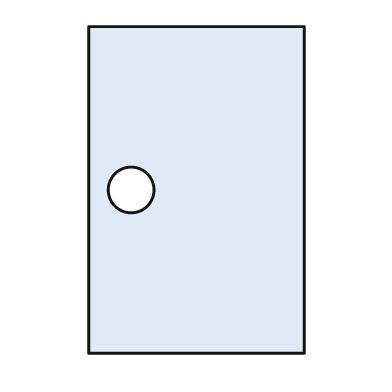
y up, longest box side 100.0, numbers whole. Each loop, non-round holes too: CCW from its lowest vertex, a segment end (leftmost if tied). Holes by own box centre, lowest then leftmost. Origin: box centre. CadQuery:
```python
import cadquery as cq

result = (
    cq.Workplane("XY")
    .moveTo(-33.0, -50.0)
    .lineTo(33.0, -50.0)
    .lineTo(33.0, 50.0)
    .lineTo(-33.0, 50.0)
    .close()
    .moveTo(-20.0, 0.0)
    .circle(7.0)
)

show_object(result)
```